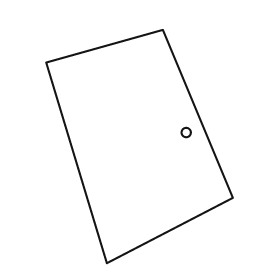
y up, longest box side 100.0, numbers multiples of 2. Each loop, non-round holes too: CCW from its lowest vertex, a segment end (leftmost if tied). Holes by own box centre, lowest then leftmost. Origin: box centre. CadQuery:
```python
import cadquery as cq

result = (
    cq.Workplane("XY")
    .moveTo(-14.0, -50.0)
    .lineTo(40.0, -22.0)
    .lineTo(10.0, 50.0)
    .lineTo(-40.0, 36.0)
    .close()
    .moveTo(20.0, 6.0)
    .circle(2.0)
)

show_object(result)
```